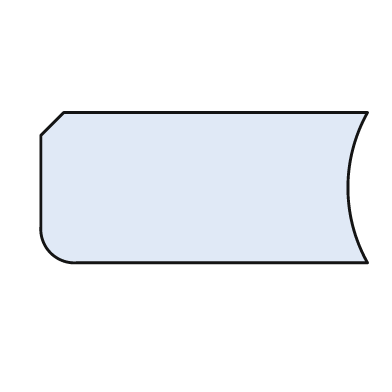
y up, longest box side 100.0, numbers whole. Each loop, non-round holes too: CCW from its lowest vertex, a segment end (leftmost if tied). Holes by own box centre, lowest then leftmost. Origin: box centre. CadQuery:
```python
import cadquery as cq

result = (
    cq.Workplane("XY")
    .moveTo(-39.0, -23.0)
    .lineTo(50.0, -23.0)
    .threePointArc((44.0, 0.0), (50.0, 23.0))
    .lineTo(-43.0, 23.0)
    .lineTo(-50.0, 16.0)
    .lineTo(-50.0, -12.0)
    .threePointArc((-47.0, -20.0), (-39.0, -23.0))
    .close()
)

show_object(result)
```